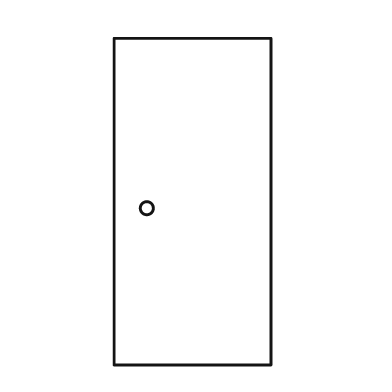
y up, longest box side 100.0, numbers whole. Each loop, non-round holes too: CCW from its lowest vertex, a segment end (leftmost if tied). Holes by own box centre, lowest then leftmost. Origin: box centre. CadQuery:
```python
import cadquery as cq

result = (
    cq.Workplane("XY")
    .moveTo(-24.0, -50.0)
    .lineTo(24.0, -50.0)
    .lineTo(24.0, 50.0)
    .lineTo(-24.0, 50.0)
    .close()
    .moveTo(-14.0, -2.0)
    .circle(2.0)
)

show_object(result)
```